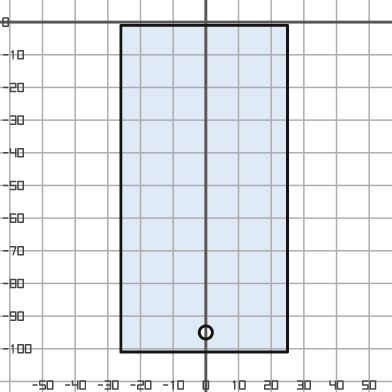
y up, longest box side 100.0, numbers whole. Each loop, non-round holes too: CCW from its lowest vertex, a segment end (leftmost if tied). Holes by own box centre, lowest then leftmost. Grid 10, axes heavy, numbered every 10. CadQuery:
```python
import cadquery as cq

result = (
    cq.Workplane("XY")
    .moveTo(-26.0, -101.0)
    .lineTo(25.0, -101.0)
    .lineTo(25.0, -1.0)
    .lineTo(-26.0, -1.0)
    .close()
    .moveTo(0.0, -95.0)
    .circle(2.0)
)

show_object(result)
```